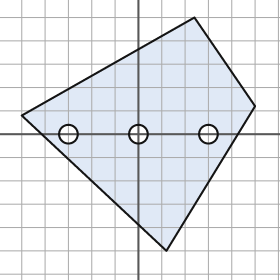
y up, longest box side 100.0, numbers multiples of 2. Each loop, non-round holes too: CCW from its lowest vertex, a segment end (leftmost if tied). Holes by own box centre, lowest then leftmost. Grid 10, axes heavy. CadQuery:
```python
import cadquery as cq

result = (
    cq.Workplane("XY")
    .moveTo(12.0, -50.0)
    .lineTo(50.0, 12.0)
    .lineTo(24.0, 50.0)
    .lineTo(-50.0, 8.0)
    .close()
    .moveTo(-30.0, 0.0)
    .circle(4.0)
    .moveTo(0.0, 0.0)
    .circle(4.0)
    .moveTo(30.0, 0.0)
    .circle(4.0)
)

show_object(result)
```